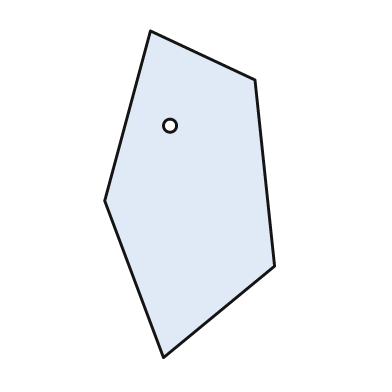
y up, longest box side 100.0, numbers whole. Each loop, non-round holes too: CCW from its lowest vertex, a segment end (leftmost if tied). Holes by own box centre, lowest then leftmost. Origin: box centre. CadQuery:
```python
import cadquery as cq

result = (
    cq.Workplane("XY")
    .moveTo(-8.0, -50.0)
    .lineTo(26.0, -22.0)
    .lineTo(20.0, 35.0)
    .lineTo(-12.0, 50.0)
    .lineTo(-26.0, -2.0)
    .close()
    .moveTo(-6.0, 21.0)
    .circle(2.0)
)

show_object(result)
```